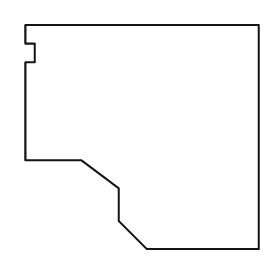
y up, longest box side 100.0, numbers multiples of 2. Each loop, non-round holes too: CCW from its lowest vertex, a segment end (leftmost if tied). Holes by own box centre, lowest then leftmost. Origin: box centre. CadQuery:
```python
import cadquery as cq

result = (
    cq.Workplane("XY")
    .moveTo(2.0, -48.0)
    .lineTo(50.0, -48.0)
    .lineTo(50.0, 48.0)
    .lineTo(-50.0, 48.0)
    .lineTo(-50.0, 40.0)
    .lineTo(-46.0, 40.0)
    .lineTo(-46.0, 32.0)
    .lineTo(-50.0, 32.0)
    .lineTo(-50.0, -10.0)
    .lineTo(-26.0, -10.0)
    .lineTo(-10.0, -22.0)
    .lineTo(-10.0, -36.0)
    .close()
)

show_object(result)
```